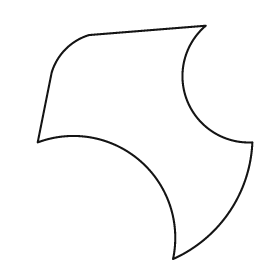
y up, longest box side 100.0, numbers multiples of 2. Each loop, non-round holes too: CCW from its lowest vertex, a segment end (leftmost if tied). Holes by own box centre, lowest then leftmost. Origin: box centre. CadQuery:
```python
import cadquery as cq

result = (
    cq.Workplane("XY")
    .moveTo(12.0, -50.0)
    .threePointArc((36.0, -30.0), (46.0, 0.0))
    .threePointArc((18.0, 18.0), (26.0, 50.0))
    .lineTo(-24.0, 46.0)
    .threePointArc((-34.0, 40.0), (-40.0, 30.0))
    .lineTo(-46.0, 0.0)
    .threePointArc((-2.0, -8.0), (12.0, -50.0))
    .close()
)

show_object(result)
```